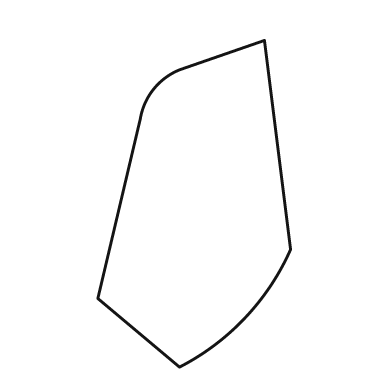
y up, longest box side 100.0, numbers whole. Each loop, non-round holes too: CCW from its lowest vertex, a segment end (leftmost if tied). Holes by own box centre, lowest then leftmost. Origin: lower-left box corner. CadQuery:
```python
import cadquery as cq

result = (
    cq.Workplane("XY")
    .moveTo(25.0, 0.0)
    .threePointArc((45.0, 15.0), (59.0, 36.0))
    .lineTo(51.0, 100.0)
    .lineTo(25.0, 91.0)
    .threePointArc((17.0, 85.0), (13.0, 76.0))
    .lineTo(0.0, 21.0)
    .close()
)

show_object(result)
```